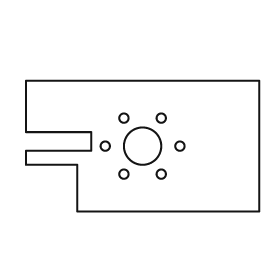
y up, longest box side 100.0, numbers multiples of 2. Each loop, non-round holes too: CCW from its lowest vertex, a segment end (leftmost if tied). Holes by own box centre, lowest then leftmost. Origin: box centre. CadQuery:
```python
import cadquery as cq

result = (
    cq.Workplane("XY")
    .moveTo(-28.0, -28.0)
    .lineTo(50.0, -28.0)
    .lineTo(50.0, 28.0)
    .lineTo(-50.0, 28.0)
    .lineTo(-50.0, 6.0)
    .lineTo(-22.0, 6.0)
    .lineTo(-22.0, -2.0)
    .lineTo(-50.0, -2.0)
    .lineTo(-50.0, -8.0)
    .lineTo(-28.0, -8.0)
    .close()
    .moveTo(-8.0, -12.0)
    .circle(2.0)
    .moveTo(8.0, -12.0)
    .circle(2.0)
    .moveTo(-16.0, 0.0)
    .circle(2.0)
    .moveTo(0.0, 0.0)
    .circle(8.0)
    .moveTo(16.0, 0.0)
    .circle(2.0)
    .moveTo(-8.0, 12.0)
    .circle(2.0)
    .moveTo(8.0, 12.0)
    .circle(2.0)
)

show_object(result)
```